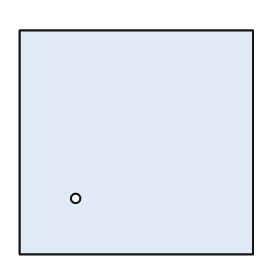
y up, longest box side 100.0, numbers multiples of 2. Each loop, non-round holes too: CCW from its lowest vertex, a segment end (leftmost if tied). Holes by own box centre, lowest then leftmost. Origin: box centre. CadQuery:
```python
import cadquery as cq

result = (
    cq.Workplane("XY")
    .moveTo(-50.0, -48.0)
    .lineTo(50.0, -48.0)
    .lineTo(50.0, 48.0)
    .lineTo(-50.0, 48.0)
    .close()
    .moveTo(-26.0, -24.0)
    .circle(2.0)
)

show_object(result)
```